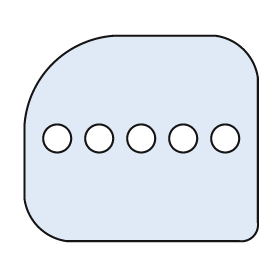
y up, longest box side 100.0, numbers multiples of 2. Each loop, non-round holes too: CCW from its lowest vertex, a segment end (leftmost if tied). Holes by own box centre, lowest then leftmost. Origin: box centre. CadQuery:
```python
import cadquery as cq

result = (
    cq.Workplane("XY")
    .moveTo(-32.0, -44.0)
    .lineTo(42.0, -44.0)
    .threePointArc((48.0, -42.0), (50.0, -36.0))
    .lineTo(50.0, 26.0)
    .threePointArc((44.0, 38.0), (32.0, 44.0))
    .lineTo(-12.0, 44.0)
    .threePointArc((-38.0, 32.0), (-50.0, 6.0))
    .lineTo(-50.0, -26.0)
    .threePointArc((-44.0, -38.0), (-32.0, -44.0))
    .close()
    .moveTo(-36.0, 0.0)
    .circle(6.0)
    .moveTo(-18.0, 0.0)
    .circle(6.0)
    .moveTo(0.0, 0.0)
    .circle(6.0)
    .moveTo(18.0, 0.0)
    .circle(6.0)
    .moveTo(36.0, 0.0)
    .circle(6.0)
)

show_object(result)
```